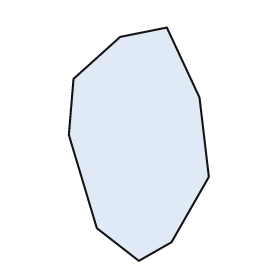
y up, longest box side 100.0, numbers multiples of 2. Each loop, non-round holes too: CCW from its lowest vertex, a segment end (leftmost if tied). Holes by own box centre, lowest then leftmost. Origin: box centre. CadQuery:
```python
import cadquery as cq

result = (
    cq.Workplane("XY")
    .moveTo(0.0, -50.0)
    .lineTo(14.0, -42.0)
    .lineTo(30.0, -14.0)
    .lineTo(26.0, 20.0)
    .lineTo(12.0, 50.0)
    .lineTo(-8.0, 46.0)
    .lineTo(-28.0, 28.0)
    .lineTo(-30.0, 4.0)
    .lineTo(-18.0, -36.0)
    .close()
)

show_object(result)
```